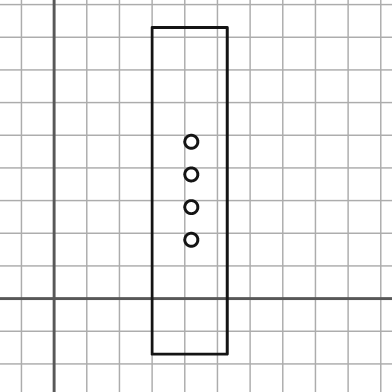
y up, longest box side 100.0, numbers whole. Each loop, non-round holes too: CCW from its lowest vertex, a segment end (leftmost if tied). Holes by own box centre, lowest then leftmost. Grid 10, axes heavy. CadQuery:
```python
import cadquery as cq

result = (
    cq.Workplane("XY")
    .moveTo(30.0, -17.0)
    .lineTo(53.0, -17.0)
    .lineTo(53.0, 83.0)
    .lineTo(30.0, 83.0)
    .close()
    .moveTo(42.0, 18.0)
    .circle(2.0)
    .moveTo(42.0, 28.0)
    .circle(2.0)
    .moveTo(42.0, 38.0)
    .circle(2.0)
    .moveTo(42.0, 48.0)
    .circle(2.0)
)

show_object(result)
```